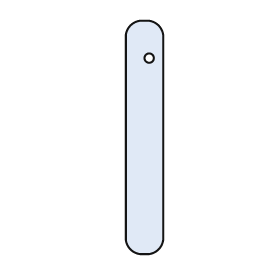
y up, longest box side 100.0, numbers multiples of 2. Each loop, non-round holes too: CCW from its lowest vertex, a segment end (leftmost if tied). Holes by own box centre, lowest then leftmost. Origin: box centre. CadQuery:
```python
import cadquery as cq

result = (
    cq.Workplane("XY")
    .moveTo(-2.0, -50.0)
    .lineTo(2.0, -50.0)
    .threePointArc((6.0, -48.0), (8.0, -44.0))
    .lineTo(8.0, 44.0)
    .threePointArc((6.0, 48.0), (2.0, 50.0))
    .lineTo(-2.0, 50.0)
    .threePointArc((-6.0, 48.0), (-8.0, 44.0))
    .lineTo(-8.0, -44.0)
    .threePointArc((-6.0, -48.0), (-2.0, -50.0))
    .close()
    .moveTo(2.0, 34.0)
    .circle(2.0)
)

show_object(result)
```